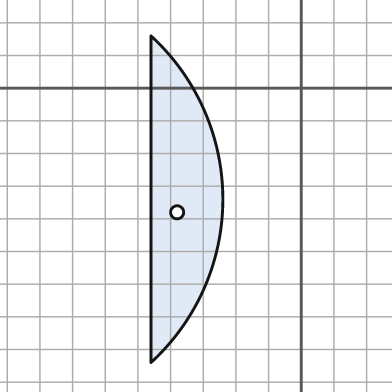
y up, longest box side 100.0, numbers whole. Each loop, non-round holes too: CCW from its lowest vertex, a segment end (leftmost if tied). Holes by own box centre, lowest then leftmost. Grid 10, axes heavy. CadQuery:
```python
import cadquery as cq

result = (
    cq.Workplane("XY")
    .moveTo(-46.0, -84.0)
    .threePointArc((-24.0, -34.0), (-46.0, 16.0))
    .close()
    .moveTo(-38.0, -38.0)
    .circle(2.0)
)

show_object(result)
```